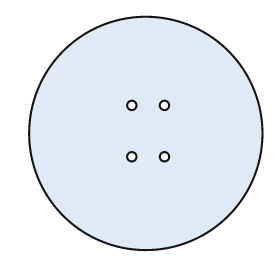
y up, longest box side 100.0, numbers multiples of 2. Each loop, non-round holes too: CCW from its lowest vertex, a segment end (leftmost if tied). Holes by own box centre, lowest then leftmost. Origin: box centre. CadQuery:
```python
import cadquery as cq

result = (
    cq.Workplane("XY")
    .moveTo(0.0, 0.0)
    .circle(50.0)
    .moveTo(-6.0, -10.0)
    .circle(2.0)
    .moveTo(8.0, -10.0)
    .circle(2.0)
    .moveTo(-6.0, 12.0)
    .circle(2.0)
    .moveTo(8.0, 12.0)
    .circle(2.0)
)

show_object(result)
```